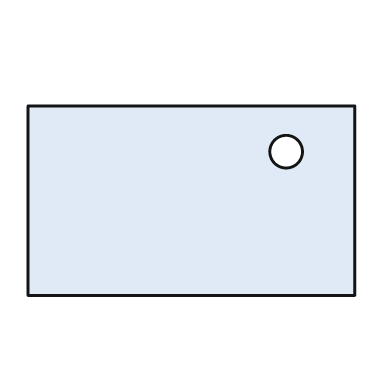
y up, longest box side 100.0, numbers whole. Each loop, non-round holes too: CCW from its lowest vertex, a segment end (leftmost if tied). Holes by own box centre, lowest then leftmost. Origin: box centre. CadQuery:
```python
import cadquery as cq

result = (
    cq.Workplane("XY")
    .moveTo(-50.0, -29.0)
    .lineTo(50.0, -29.0)
    .lineTo(50.0, 29.0)
    .lineTo(-50.0, 29.0)
    .close()
    .moveTo(29.0, 15.0)
    .circle(5.0)
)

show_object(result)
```